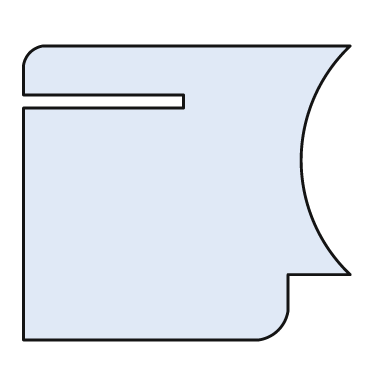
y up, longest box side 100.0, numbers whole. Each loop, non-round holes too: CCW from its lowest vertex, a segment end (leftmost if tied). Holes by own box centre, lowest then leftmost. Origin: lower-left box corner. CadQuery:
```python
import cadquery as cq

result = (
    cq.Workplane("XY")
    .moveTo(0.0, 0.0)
    .lineTo(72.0, 0.0)
    .threePointArc((78.0, 3.0), (81.0, 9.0))
    .lineTo(81.0, 20.0)
    .lineTo(100.0, 20.0)
    .threePointArc((85.0, 55.0), (100.0, 90.0))
    .lineTo(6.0, 90.0)
    .threePointArc((2.0, 88.0), (0.0, 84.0))
    .lineTo(0.0, 75.0)
    .lineTo(49.0, 75.0)
    .lineTo(49.0, 71.0)
    .lineTo(0.0, 71.0)
    .close()
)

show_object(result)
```